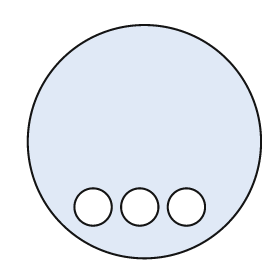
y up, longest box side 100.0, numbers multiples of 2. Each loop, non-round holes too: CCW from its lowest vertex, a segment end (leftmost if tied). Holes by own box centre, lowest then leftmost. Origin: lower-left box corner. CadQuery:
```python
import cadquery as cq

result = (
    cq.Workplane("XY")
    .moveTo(50.0, 50.0)
    .circle(50.0)
    .moveTo(28.0, 22.0)
    .circle(8.0)
    .moveTo(48.0, 22.0)
    .circle(8.0)
    .moveTo(68.0, 22.0)
    .circle(8.0)
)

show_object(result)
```